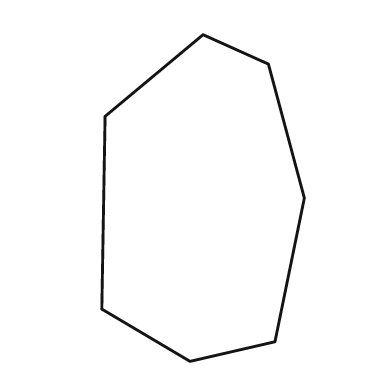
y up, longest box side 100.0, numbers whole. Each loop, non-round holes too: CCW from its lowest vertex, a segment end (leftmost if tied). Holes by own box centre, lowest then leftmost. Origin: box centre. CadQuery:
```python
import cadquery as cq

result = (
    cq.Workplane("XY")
    .moveTo(-4.0, -50.0)
    .lineTo(22.0, -44.0)
    .lineTo(31.0, 0.0)
    .lineTo(20.0, 41.0)
    .lineTo(0.0, 50.0)
    .lineTo(-30.0, 25.0)
    .lineTo(-31.0, -34.0)
    .close()
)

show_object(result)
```